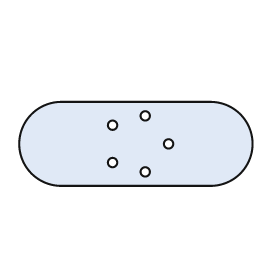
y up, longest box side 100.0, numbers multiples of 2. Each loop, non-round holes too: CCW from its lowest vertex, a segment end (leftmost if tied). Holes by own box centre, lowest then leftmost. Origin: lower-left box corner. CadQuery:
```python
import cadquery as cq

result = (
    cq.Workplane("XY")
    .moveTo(18.0, 0.0)
    .lineTo(82.0, 0.0)
    .threePointArc((100.0, 18.0), (82.0, 36.0))
    .lineTo(18.0, 36.0)
    .threePointArc((0.0, 18.0), (18.0, 0.0))
    .close()
    .moveTo(54.0, 6.0)
    .circle(2.0)
    .moveTo(40.0, 10.0)
    .circle(2.0)
    .moveTo(64.0, 18.0)
    .circle(2.0)
    .moveTo(40.0, 26.0)
    .circle(2.0)
    .moveTo(54.0, 30.0)
    .circle(2.0)
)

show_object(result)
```